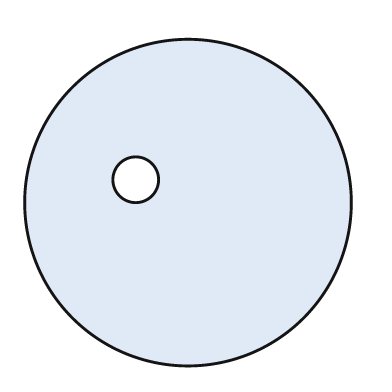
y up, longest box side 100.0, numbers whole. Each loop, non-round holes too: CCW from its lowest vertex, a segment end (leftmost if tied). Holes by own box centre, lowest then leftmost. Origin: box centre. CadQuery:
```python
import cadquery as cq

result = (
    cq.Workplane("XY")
    .moveTo(0.0, 0.0)
    .circle(50.0)
    .moveTo(-16.0, 7.0)
    .circle(7.0)
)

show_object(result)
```